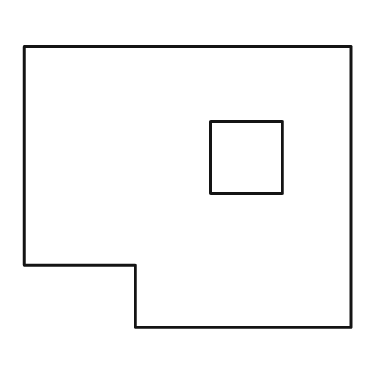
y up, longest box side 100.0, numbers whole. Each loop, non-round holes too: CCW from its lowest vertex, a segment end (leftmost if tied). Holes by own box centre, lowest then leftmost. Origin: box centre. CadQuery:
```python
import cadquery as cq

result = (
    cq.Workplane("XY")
    .moveTo(-16.0, -43.0)
    .lineTo(50.0, -43.0)
    .lineTo(50.0, 43.0)
    .lineTo(-50.0, 43.0)
    .lineTo(-50.0, -24.0)
    .lineTo(-16.0, -24.0)
    .close()
    .moveTo(7.0, -2.0)
    .lineTo(29.0, -2.0)
    .lineTo(29.0, 20.0)
    .lineTo(7.0, 20.0)
    .close()
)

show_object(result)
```